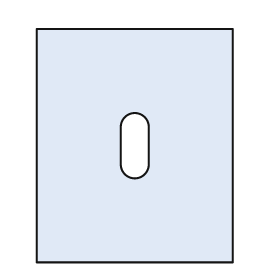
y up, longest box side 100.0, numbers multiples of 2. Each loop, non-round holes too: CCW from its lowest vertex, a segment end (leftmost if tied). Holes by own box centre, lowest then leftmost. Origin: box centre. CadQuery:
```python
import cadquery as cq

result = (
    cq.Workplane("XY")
    .moveTo(-42.0, -50.0)
    .lineTo(42.0, -50.0)
    .lineTo(42.0, 50.0)
    .lineTo(-42.0, 50.0)
    .close()
    .moveTo(-6.0, -8.0)
    .threePointArc((0.0, -14.0), (6.0, -8.0))
    .lineTo(6.0, 8.0)
    .threePointArc((0.0, 14.0), (-6.0, 8.0))
    .close()
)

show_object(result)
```